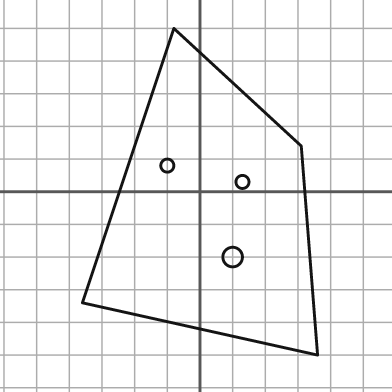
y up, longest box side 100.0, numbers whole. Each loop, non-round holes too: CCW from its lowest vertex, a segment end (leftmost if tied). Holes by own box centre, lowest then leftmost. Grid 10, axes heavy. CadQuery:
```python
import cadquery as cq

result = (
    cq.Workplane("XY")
    .moveTo(36.0, -50.0)
    .lineTo(31.0, 14.0)
    .lineTo(-8.0, 50.0)
    .lineTo(-36.0, -34.0)
    .close()
    .moveTo(10.0, -20.0)
    .circle(3.0)
    .moveTo(13.0, 3.0)
    .circle(2.0)
    .moveTo(-10.0, 8.0)
    .circle(2.0)
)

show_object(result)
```